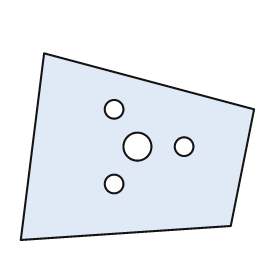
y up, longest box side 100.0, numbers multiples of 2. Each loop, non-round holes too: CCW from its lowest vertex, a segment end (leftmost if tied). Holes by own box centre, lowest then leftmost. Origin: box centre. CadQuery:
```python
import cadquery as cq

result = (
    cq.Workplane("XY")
    .moveTo(-50.0, -40.0)
    .lineTo(40.0, -34.0)
    .lineTo(50.0, 16.0)
    .lineTo(-40.0, 40.0)
    .close()
    .moveTo(-10.0, -16.0)
    .circle(4.0)
    .moveTo(0.0, 0.0)
    .circle(6.0)
    .moveTo(20.0, 0.0)
    .circle(4.0)
    .moveTo(-10.0, 16.0)
    .circle(4.0)
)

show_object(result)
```